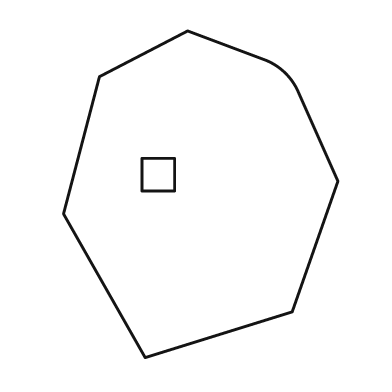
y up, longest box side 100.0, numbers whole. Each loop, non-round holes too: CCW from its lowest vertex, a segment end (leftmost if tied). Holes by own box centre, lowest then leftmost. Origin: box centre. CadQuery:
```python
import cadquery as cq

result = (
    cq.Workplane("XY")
    .moveTo(-17.0, -50.0)
    .lineTo(28.0, -36.0)
    .lineTo(42.0, 4.0)
    .lineTo(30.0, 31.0)
    .threePointArc((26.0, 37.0), (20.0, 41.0))
    .lineTo(-4.0, 50.0)
    .lineTo(-31.0, 36.0)
    .lineTo(-42.0, -6.0)
    .close()
    .moveTo(-18.0, 1.0)
    .lineTo(-8.0, 1.0)
    .lineTo(-8.0, 11.0)
    .lineTo(-18.0, 11.0)
    .close()
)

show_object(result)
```